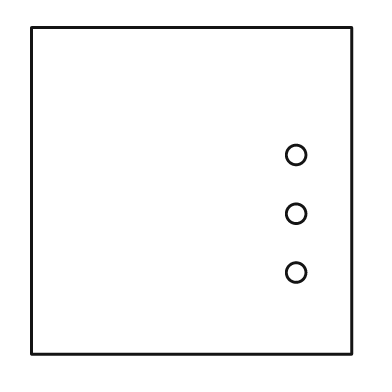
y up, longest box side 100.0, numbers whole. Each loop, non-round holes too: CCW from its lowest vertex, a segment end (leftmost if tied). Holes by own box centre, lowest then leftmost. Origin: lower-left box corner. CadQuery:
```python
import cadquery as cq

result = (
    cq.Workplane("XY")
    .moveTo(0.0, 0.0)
    .lineTo(98.0, 0.0)
    .lineTo(98.0, 100.0)
    .lineTo(0.0, 100.0)
    .close()
    .moveTo(81.0, 25.0)
    .circle(3.0)
    .moveTo(81.0, 43.0)
    .circle(3.0)
    .moveTo(81.0, 61.0)
    .circle(3.0)
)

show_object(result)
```